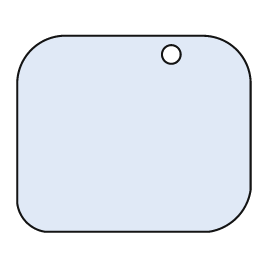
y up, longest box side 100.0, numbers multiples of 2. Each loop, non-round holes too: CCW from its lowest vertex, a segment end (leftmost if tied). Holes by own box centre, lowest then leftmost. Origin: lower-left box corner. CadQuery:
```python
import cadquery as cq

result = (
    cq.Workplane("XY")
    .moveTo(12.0, 0.0)
    .lineTo(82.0, 0.0)
    .threePointArc((94.0, 6.0), (100.0, 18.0))
    .lineTo(100.0, 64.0)
    .threePointArc((94.0, 78.0), (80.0, 84.0))
    .lineTo(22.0, 84.0)
    .threePointArc((6.0, 78.0), (0.0, 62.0))
    .lineTo(0.0, 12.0)
    .threePointArc((4.0, 4.0), (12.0, 0.0))
    .close()
    .moveTo(66.0, 76.0)
    .circle(4.0)
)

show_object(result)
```